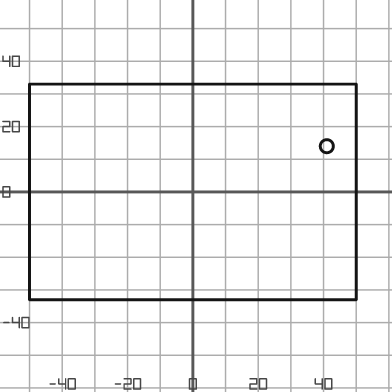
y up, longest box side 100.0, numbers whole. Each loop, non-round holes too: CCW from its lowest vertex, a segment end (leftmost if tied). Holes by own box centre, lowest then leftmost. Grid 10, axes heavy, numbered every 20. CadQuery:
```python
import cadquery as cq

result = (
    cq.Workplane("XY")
    .moveTo(-50.0, -33.0)
    .lineTo(50.0, -33.0)
    .lineTo(50.0, 33.0)
    .lineTo(-50.0, 33.0)
    .close()
    .moveTo(41.0, 14.0)
    .circle(2.0)
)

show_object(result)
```